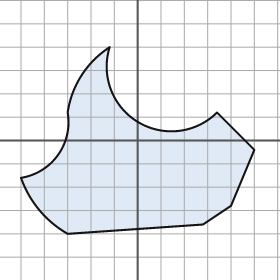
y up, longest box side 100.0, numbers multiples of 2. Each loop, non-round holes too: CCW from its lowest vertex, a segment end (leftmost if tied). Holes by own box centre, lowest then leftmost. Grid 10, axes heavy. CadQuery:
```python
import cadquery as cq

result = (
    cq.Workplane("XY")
    .moveTo(-30.0, -40.0)
    .lineTo(28.0, -36.0)
    .lineTo(40.0, -28.0)
    .lineTo(50.0, -4.0)
    .lineTo(34.0, 12.0)
    .threePointArc((0.0, 8.0), (-12.0, 40.0))
    .threePointArc((-24.0, 28.0), (-30.0, 12.0))
    .threePointArc((-34.0, -6.0), (-50.0, -16.0))
    .threePointArc((-42.0, -30.0), (-30.0, -40.0))
    .close()
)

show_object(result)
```